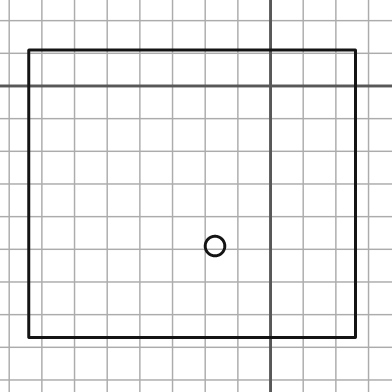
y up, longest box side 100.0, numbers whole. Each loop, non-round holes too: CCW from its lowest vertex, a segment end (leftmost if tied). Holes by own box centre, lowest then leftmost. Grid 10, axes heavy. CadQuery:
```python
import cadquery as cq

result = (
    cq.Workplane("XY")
    .moveTo(-74.0, -77.0)
    .lineTo(26.0, -77.0)
    .lineTo(26.0, 11.0)
    .lineTo(-74.0, 11.0)
    .close()
    .moveTo(-17.0, -49.0)
    .circle(3.0)
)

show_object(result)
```